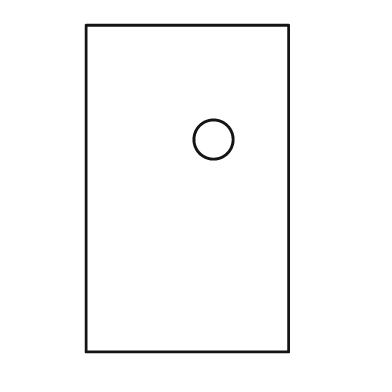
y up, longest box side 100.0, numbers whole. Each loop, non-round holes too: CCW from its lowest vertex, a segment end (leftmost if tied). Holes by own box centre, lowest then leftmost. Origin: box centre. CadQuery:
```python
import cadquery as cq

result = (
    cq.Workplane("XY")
    .moveTo(-31.0, -50.0)
    .lineTo(31.0, -50.0)
    .lineTo(31.0, 50.0)
    .lineTo(-31.0, 50.0)
    .close()
    .moveTo(8.0, 15.0)
    .circle(6.0)
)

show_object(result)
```